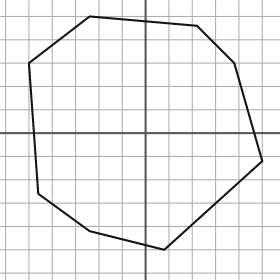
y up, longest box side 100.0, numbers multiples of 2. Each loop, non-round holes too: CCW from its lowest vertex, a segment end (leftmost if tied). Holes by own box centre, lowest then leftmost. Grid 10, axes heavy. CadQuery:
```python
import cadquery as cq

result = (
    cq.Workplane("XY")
    .moveTo(8.0, -50.0)
    .lineTo(50.0, -12.0)
    .lineTo(38.0, 30.0)
    .lineTo(22.0, 46.0)
    .lineTo(-24.0, 50.0)
    .lineTo(-50.0, 30.0)
    .lineTo(-46.0, -26.0)
    .lineTo(-24.0, -42.0)
    .close()
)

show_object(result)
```